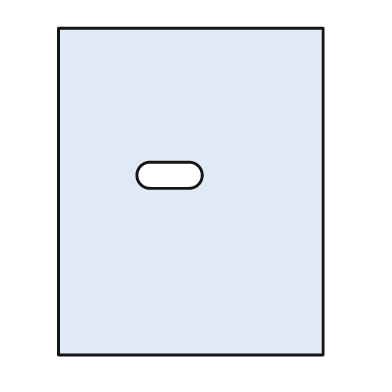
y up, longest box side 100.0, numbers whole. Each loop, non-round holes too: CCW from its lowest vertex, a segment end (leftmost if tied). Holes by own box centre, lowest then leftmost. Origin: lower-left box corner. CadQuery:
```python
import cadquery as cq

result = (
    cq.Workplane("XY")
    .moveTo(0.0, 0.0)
    .lineTo(81.0, 0.0)
    .lineTo(81.0, 100.0)
    .lineTo(0.0, 100.0)
    .close()
    .moveTo(28.0, 51.0)
    .lineTo(40.0, 51.0)
    .threePointArc((44.0, 55.0), (40.0, 59.0))
    .lineTo(28.0, 59.0)
    .threePointArc((24.0, 55.0), (28.0, 51.0))
    .close()
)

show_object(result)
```